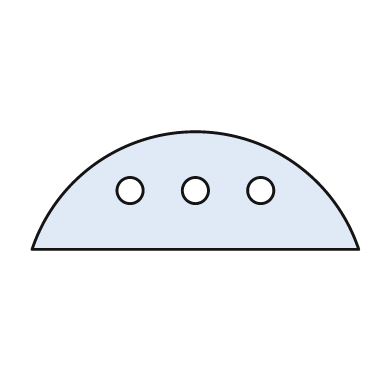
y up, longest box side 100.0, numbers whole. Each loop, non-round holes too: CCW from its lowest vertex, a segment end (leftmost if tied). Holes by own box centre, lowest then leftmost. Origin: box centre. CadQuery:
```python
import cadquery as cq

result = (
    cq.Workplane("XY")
    .moveTo(-50.0, -18.0)
    .lineTo(50.0, -18.0)
    .threePointArc((0.0, 18.0), (-50.0, -18.0))
    .close()
    .moveTo(-20.0, 0.0)
    .circle(4.0)
    .moveTo(0.0, 0.0)
    .circle(4.0)
    .moveTo(20.0, 0.0)
    .circle(4.0)
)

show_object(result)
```